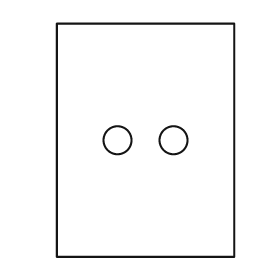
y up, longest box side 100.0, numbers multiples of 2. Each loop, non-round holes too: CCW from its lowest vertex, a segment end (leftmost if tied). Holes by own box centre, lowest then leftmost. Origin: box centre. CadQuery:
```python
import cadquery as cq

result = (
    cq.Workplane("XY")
    .moveTo(-38.0, -50.0)
    .lineTo(38.0, -50.0)
    .lineTo(38.0, 50.0)
    .lineTo(-38.0, 50.0)
    .close()
    .moveTo(-12.0, 0.0)
    .circle(6.0)
    .moveTo(12.0, 0.0)
    .circle(6.0)
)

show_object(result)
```